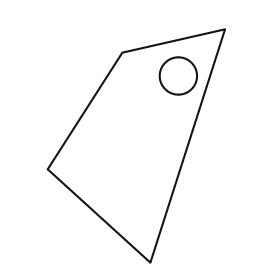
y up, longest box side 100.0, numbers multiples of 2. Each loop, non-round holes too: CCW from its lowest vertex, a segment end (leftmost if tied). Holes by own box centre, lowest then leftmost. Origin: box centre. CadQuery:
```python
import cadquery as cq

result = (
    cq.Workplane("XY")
    .moveTo(6.0, -50.0)
    .lineTo(38.0, 50.0)
    .lineTo(-6.0, 40.0)
    .lineTo(-38.0, -10.0)
    .close()
    .moveTo(18.0, 30.0)
    .circle(8.0)
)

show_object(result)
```